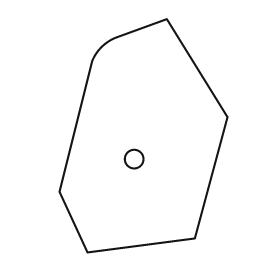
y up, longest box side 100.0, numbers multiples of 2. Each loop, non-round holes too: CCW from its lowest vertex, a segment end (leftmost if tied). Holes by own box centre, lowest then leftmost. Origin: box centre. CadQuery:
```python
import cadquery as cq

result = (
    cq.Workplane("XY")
    .moveTo(-24.0, -50.0)
    .lineTo(22.0, -44.0)
    .lineTo(36.0, 8.0)
    .lineTo(10.0, 50.0)
    .lineTo(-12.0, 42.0)
    .threePointArc((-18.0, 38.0), (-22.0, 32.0))
    .lineTo(-36.0, -24.0)
    .close()
    .moveTo(-4.0, -10.0)
    .circle(4.0)
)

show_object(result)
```